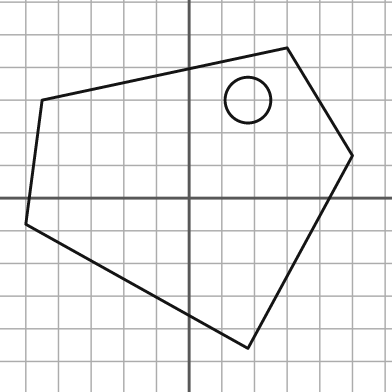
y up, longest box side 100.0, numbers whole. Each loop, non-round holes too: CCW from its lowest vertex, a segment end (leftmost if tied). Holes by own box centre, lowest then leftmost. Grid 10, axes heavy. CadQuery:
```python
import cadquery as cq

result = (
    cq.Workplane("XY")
    .moveTo(18.0, -46.0)
    .lineTo(50.0, 13.0)
    .lineTo(30.0, 46.0)
    .lineTo(-45.0, 30.0)
    .lineTo(-50.0, -8.0)
    .close()
    .moveTo(18.0, 30.0)
    .circle(7.0)
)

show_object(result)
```